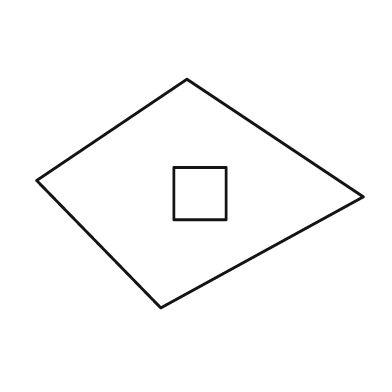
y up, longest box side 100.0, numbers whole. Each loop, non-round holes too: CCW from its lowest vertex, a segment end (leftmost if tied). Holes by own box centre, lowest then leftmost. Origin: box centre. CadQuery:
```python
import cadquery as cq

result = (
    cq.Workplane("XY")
    .moveTo(-12.0, -35.0)
    .lineTo(50.0, -1.0)
    .lineTo(-4.0, 35.0)
    .lineTo(-50.0, 4.0)
    .close()
    .moveTo(-8.0, -8.0)
    .lineTo(8.0, -8.0)
    .lineTo(8.0, 8.0)
    .lineTo(-8.0, 8.0)
    .close()
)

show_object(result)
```